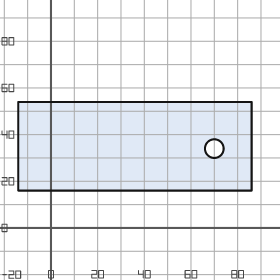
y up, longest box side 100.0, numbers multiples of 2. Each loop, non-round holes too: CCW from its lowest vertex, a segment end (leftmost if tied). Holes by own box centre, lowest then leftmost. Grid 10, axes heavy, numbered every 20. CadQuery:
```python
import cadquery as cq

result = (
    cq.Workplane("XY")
    .moveTo(-14.0, 16.0)
    .lineTo(86.0, 16.0)
    .lineTo(86.0, 54.0)
    .lineTo(-14.0, 54.0)
    .close()
    .moveTo(70.0, 34.0)
    .circle(4.0)
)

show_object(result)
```